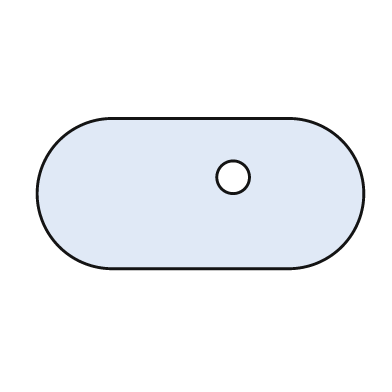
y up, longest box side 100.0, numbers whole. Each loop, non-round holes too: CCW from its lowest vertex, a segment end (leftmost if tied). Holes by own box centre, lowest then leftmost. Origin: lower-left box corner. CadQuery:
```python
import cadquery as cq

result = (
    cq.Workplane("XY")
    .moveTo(23.0, 0.0)
    .lineTo(77.0, 0.0)
    .threePointArc((100.0, 23.0), (77.0, 46.0))
    .lineTo(23.0, 46.0)
    .threePointArc((0.0, 23.0), (23.0, 0.0))
    .close()
    .moveTo(60.0, 28.0)
    .circle(5.0)
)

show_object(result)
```